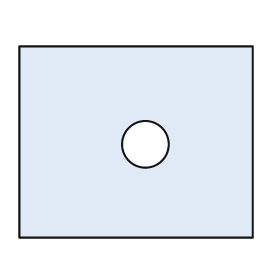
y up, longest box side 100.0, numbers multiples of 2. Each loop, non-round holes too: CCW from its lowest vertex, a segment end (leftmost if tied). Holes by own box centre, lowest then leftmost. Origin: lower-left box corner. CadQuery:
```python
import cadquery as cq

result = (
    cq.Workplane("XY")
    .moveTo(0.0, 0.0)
    .lineTo(100.0, 0.0)
    .lineTo(100.0, 82.0)
    .lineTo(0.0, 82.0)
    .close()
    .moveTo(54.0, 40.0)
    .circle(10.0)
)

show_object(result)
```